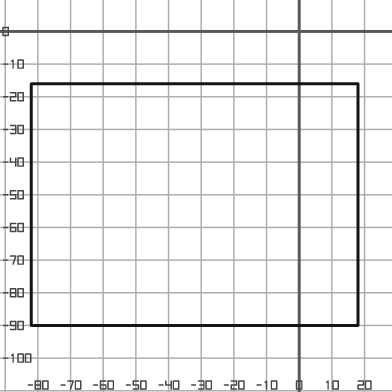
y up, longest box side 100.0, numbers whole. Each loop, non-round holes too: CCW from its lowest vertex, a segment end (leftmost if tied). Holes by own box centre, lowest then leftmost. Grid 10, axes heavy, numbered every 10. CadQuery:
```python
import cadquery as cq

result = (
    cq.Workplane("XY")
    .moveTo(-82.0, -90.0)
    .lineTo(18.0, -90.0)
    .lineTo(18.0, -16.0)
    .lineTo(-82.0, -16.0)
    .close()
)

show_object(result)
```